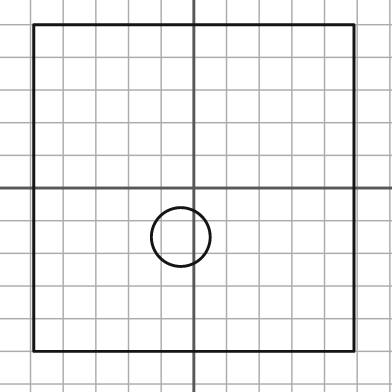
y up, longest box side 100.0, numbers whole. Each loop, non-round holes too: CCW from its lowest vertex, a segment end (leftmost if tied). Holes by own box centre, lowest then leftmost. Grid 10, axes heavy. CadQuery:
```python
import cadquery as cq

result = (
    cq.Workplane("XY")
    .moveTo(-49.0, -50.0)
    .lineTo(49.0, -50.0)
    .lineTo(49.0, 50.0)
    .lineTo(-49.0, 50.0)
    .close()
    .moveTo(-4.0, -15.0)
    .circle(9.0)
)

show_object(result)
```